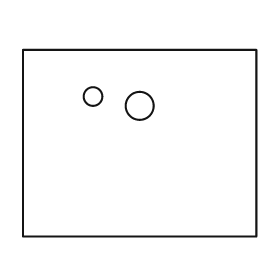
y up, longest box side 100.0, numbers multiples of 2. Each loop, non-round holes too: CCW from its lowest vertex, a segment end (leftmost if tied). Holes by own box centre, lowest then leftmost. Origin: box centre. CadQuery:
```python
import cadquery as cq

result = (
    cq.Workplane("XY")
    .moveTo(-50.0, -40.0)
    .lineTo(50.0, -40.0)
    .lineTo(50.0, 40.0)
    .lineTo(-50.0, 40.0)
    .close()
    .moveTo(0.0, 16.0)
    .circle(6.0)
    .moveTo(-20.0, 20.0)
    .circle(4.0)
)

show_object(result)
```